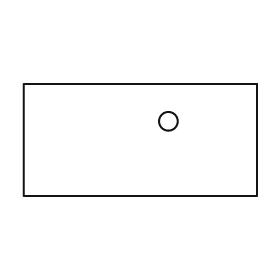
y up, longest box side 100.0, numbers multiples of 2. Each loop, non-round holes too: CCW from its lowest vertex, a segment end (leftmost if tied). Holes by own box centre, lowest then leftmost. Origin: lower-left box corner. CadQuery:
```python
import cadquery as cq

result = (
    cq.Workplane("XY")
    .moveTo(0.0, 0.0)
    .lineTo(100.0, 0.0)
    .lineTo(100.0, 48.0)
    .lineTo(0.0, 48.0)
    .close()
    .moveTo(62.0, 32.0)
    .circle(4.0)
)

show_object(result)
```